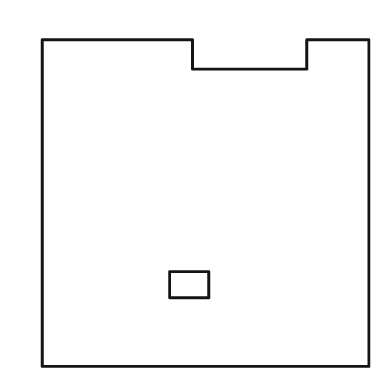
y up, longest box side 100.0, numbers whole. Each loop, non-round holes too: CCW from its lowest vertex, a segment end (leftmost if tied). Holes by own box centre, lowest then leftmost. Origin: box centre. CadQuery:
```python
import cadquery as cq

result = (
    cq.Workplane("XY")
    .moveTo(-50.0, -50.0)
    .lineTo(50.0, -50.0)
    .lineTo(50.0, 50.0)
    .lineTo(31.0, 50.0)
    .lineTo(31.0, 41.0)
    .lineTo(-4.0, 41.0)
    .lineTo(-4.0, 50.0)
    .lineTo(-50.0, 50.0)
    .close()
    .moveTo(-11.0, -29.0)
    .lineTo(1.0, -29.0)
    .lineTo(1.0, -21.0)
    .lineTo(-11.0, -21.0)
    .close()
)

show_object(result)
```